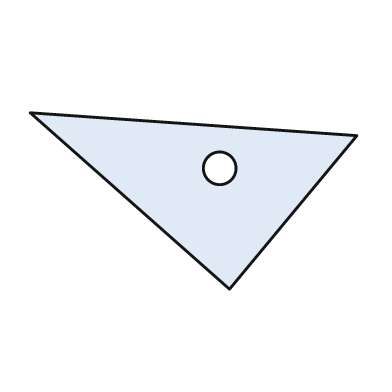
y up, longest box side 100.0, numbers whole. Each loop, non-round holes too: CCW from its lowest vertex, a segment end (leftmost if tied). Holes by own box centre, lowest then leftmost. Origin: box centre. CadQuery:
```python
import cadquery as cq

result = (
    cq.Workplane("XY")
    .moveTo(11.0, -27.0)
    .lineTo(50.0, 20.0)
    .lineTo(-50.0, 27.0)
    .close()
    .moveTo(8.0, 10.0)
    .circle(5.0)
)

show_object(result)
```